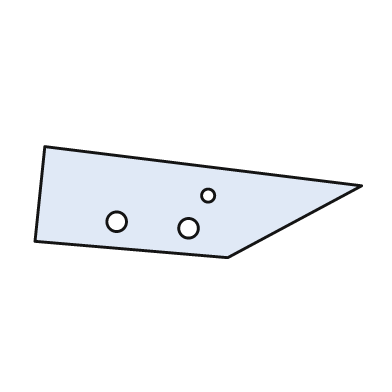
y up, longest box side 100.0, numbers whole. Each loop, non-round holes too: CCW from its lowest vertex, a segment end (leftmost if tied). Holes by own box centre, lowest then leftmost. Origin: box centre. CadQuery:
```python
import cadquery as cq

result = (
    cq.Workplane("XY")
    .moveTo(9.0, -17.0)
    .lineTo(50.0, 5.0)
    .lineTo(-47.0, 17.0)
    .lineTo(-50.0, -12.0)
    .close()
    .moveTo(-3.0, -8.0)
    .circle(3.0)
    .moveTo(-25.0, -6.0)
    .circle(3.0)
    .moveTo(3.0, 2.0)
    .circle(2.0)
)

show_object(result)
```